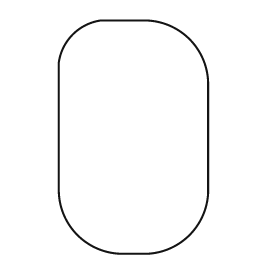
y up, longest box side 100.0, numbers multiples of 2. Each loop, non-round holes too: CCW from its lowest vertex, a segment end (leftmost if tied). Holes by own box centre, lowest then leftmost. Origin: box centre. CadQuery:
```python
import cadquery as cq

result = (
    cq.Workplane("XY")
    .moveTo(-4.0, -50.0)
    .lineTo(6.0, -50.0)
    .threePointArc((24.0, -42.0), (32.0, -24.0))
    .lineTo(32.0, 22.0)
    .threePointArc((24.0, 42.0), (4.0, 50.0))
    .lineTo(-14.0, 50.0)
    .threePointArc((-26.0, 44.0), (-32.0, 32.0))
    .lineTo(-32.0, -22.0)
    .threePointArc((-24.0, -42.0), (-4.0, -50.0))
    .close()
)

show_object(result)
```